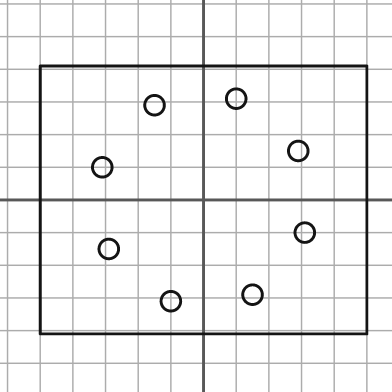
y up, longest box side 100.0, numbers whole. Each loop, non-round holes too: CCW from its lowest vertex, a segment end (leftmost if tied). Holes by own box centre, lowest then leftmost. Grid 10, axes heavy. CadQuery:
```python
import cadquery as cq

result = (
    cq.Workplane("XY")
    .moveTo(-50.0, -41.0)
    .lineTo(50.0, -41.0)
    .lineTo(50.0, 41.0)
    .lineTo(-50.0, 41.0)
    .close()
    .moveTo(-10.0, -31.0)
    .circle(3.0)
    .moveTo(15.0, -29.0)
    .circle(3.0)
    .moveTo(-29.0, -15.0)
    .circle(3.0)
    .moveTo(31.0, -10.0)
    .circle(3.0)
    .moveTo(-31.0, 10.0)
    .circle(3.0)
    .moveTo(29.0, 15.0)
    .circle(3.0)
    .moveTo(-15.0, 29.0)
    .circle(3.0)
    .moveTo(10.0, 31.0)
    .circle(3.0)
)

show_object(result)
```